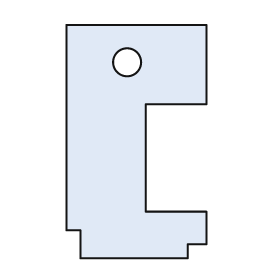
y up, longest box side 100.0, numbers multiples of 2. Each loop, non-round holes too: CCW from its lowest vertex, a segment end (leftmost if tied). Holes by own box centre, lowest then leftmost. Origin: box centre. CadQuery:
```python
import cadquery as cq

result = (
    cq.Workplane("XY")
    .moveTo(-24.0, -50.0)
    .lineTo(22.0, -50.0)
    .lineTo(22.0, -44.0)
    .lineTo(30.0, -44.0)
    .lineTo(30.0, -30.0)
    .lineTo(4.0, -30.0)
    .lineTo(4.0, 16.0)
    .lineTo(30.0, 16.0)
    .lineTo(30.0, 50.0)
    .lineTo(-30.0, 50.0)
    .lineTo(-30.0, -38.0)
    .lineTo(-24.0, -38.0)
    .close()
    .moveTo(-4.0, 34.0)
    .circle(6.0)
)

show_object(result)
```